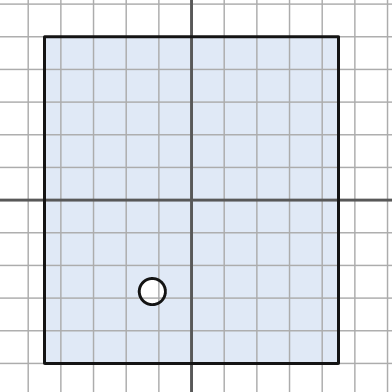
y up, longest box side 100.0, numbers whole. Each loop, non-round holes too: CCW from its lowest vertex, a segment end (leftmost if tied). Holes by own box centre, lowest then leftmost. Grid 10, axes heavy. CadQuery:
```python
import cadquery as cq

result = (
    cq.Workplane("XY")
    .moveTo(-45.0, -50.0)
    .lineTo(45.0, -50.0)
    .lineTo(45.0, 50.0)
    .lineTo(-45.0, 50.0)
    .close()
    .moveTo(-12.0, -28.0)
    .circle(4.0)
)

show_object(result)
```